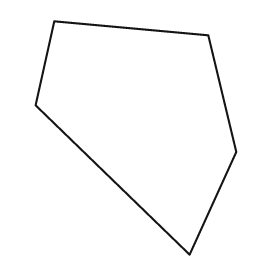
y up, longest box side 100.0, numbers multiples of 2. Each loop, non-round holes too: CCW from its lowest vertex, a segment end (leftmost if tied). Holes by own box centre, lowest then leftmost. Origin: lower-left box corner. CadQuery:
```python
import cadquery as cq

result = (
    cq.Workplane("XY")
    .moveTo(66.0, 0.0)
    .lineTo(86.0, 44.0)
    .lineTo(74.0, 94.0)
    .lineTo(8.0, 100.0)
    .lineTo(0.0, 64.0)
    .close()
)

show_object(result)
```